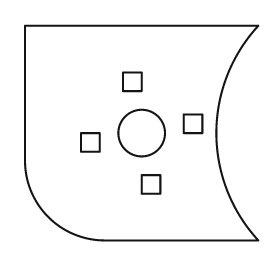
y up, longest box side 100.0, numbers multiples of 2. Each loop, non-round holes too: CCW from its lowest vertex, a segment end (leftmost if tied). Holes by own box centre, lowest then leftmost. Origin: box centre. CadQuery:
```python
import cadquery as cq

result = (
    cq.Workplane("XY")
    .moveTo(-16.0, -46.0)
    .lineTo(50.0, -46.0)
    .threePointArc((32.0, 0.0), (50.0, 46.0))
    .lineTo(-50.0, 46.0)
    .lineTo(-50.0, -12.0)
    .threePointArc((-40.0, -36.0), (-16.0, -46.0))
    .close()
    .moveTo(0.0, -26.0)
    .lineTo(8.0, -26.0)
    .lineTo(8.0, -18.0)
    .lineTo(0.0, -18.0)
    .close()
    .moveTo(-26.0, -8.0)
    .lineTo(-18.0, -8.0)
    .lineTo(-18.0, 0.0)
    .lineTo(-26.0, 0.0)
    .close()
    .moveTo(0.0, 0.0)
    .circle(10.0)
    .moveTo(18.0, 0.0)
    .lineTo(26.0, 0.0)
    .lineTo(26.0, 8.0)
    .lineTo(18.0, 8.0)
    .close()
    .moveTo(-8.0, 18.0)
    .lineTo(0.0, 18.0)
    .lineTo(0.0, 26.0)
    .lineTo(-8.0, 26.0)
    .close()
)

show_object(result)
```